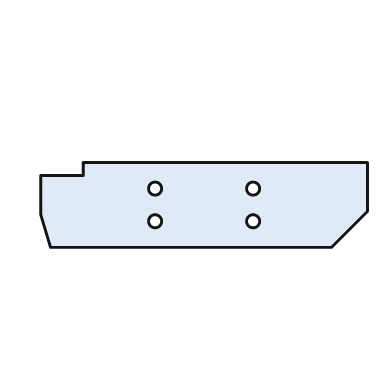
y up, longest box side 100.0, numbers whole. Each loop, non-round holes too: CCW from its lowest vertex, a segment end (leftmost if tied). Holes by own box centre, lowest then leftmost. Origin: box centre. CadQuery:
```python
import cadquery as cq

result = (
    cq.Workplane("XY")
    .moveTo(-47.0, -13.0)
    .lineTo(39.0, -13.0)
    .lineTo(50.0, -2.0)
    .lineTo(50.0, 13.0)
    .lineTo(-37.0, 13.0)
    .lineTo(-37.0, 9.0)
    .lineTo(-50.0, 9.0)
    .lineTo(-50.0, -3.0)
    .close()
    .moveTo(-15.0, -5.0)
    .circle(2.0)
    .moveTo(15.0, -5.0)
    .circle(2.0)
    .moveTo(-15.0, 5.0)
    .circle(2.0)
    .moveTo(15.0, 5.0)
    .circle(2.0)
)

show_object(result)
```